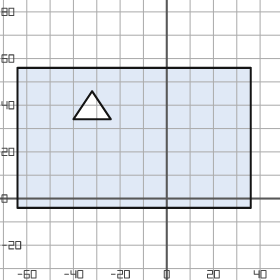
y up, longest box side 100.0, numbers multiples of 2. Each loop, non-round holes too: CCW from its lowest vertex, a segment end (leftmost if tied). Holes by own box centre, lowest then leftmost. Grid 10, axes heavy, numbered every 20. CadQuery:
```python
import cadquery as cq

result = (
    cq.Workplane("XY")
    .moveTo(-64.0, -4.0)
    .lineTo(36.0, -4.0)
    .lineTo(36.0, 56.0)
    .lineTo(-64.0, 56.0)
    .close()
    .moveTo(-40.0, 34.0)
    .lineTo(-24.0, 34.0)
    .lineTo(-32.0, 46.0)
    .close()
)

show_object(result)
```